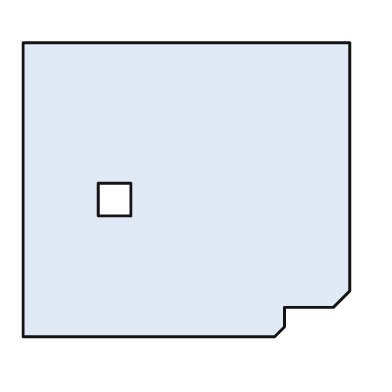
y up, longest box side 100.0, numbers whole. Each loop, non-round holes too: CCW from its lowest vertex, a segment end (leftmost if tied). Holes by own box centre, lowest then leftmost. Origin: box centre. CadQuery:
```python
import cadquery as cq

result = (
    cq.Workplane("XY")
    .moveTo(-50.0, -45.0)
    .lineTo(27.0, -45.0)
    .lineTo(30.0, -42.0)
    .lineTo(30.0, -36.0)
    .lineTo(45.0, -36.0)
    .lineTo(50.0, -31.0)
    .lineTo(50.0, 45.0)
    .lineTo(-50.0, 45.0)
    .close()
    .moveTo(-27.0, -8.0)
    .lineTo(-17.0, -8.0)
    .lineTo(-17.0, 2.0)
    .lineTo(-27.0, 2.0)
    .close()
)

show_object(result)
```